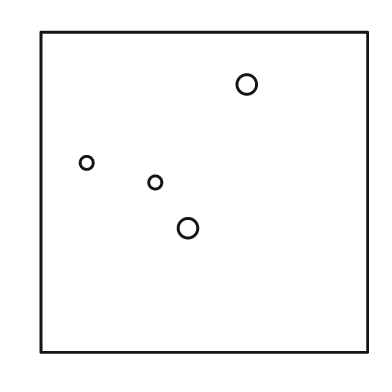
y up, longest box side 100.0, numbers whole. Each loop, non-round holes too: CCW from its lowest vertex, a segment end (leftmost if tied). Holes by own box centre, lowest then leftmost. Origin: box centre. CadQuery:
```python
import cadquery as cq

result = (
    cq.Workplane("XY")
    .moveTo(-50.0, -49.0)
    .lineTo(50.0, -49.0)
    .lineTo(50.0, 49.0)
    .lineTo(-50.0, 49.0)
    .close()
    .moveTo(-5.0, -11.0)
    .circle(3.0)
    .moveTo(-15.0, 3.0)
    .circle(2.0)
    .moveTo(-36.0, 9.0)
    .circle(2.0)
    .moveTo(13.0, 33.0)
    .circle(3.0)
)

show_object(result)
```